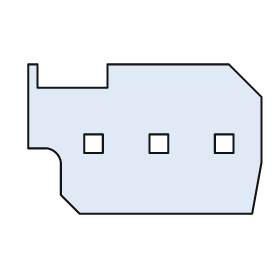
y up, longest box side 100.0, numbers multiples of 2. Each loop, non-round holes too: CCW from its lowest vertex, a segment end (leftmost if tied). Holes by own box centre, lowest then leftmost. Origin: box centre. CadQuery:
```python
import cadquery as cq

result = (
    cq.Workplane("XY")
    .moveTo(-28.0, -32.0)
    .lineTo(46.0, -32.0)
    .lineTo(50.0, -10.0)
    .lineTo(50.0, 18.0)
    .lineTo(36.0, 32.0)
    .lineTo(-16.0, 32.0)
    .lineTo(-16.0, 22.0)
    .lineTo(-46.0, 22.0)
    .lineTo(-46.0, 32.0)
    .lineTo(-50.0, 32.0)
    .lineTo(-50.0, -4.0)
    .lineTo(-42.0, -4.0)
    .threePointArc((-38.0, -6.0), (-36.0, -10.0))
    .lineTo(-36.0, -24.0)
    .close()
    .moveTo(-26.0, -6.0)
    .lineTo(-18.0, -6.0)
    .lineTo(-18.0, 2.0)
    .lineTo(-26.0, 2.0)
    .close()
    .moveTo(2.0, -6.0)
    .lineTo(10.0, -6.0)
    .lineTo(10.0, 2.0)
    .lineTo(2.0, 2.0)
    .close()
    .moveTo(30.0, -6.0)
    .lineTo(38.0, -6.0)
    .lineTo(38.0, 2.0)
    .lineTo(30.0, 2.0)
    .close()
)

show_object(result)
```